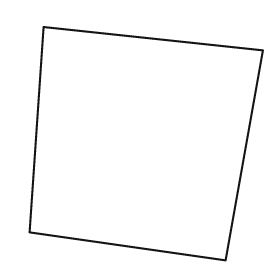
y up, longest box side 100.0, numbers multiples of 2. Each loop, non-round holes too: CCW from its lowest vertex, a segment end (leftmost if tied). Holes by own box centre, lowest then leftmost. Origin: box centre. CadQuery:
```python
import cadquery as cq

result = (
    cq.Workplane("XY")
    .moveTo(34.0, -50.0)
    .lineTo(50.0, 40.0)
    .lineTo(-44.0, 50.0)
    .lineTo(-50.0, -38.0)
    .close()
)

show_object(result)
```